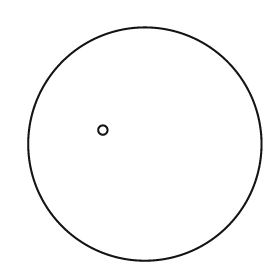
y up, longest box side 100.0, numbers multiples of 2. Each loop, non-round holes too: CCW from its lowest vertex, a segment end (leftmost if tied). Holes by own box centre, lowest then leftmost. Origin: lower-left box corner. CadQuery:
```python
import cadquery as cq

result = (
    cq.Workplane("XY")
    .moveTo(50.0, 50.0)
    .circle(50.0)
    .moveTo(32.0, 56.0)
    .circle(2.0)
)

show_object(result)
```